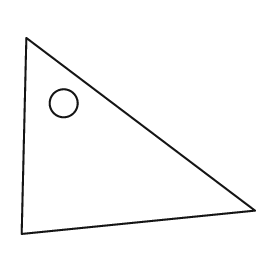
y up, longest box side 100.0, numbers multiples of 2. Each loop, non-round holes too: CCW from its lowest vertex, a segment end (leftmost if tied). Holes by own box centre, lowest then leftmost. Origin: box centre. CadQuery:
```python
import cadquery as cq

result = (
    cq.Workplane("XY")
    .moveTo(-50.0, -42.0)
    .lineTo(50.0, -32.0)
    .lineTo(-48.0, 42.0)
    .close()
    .moveTo(-32.0, 14.0)
    .circle(6.0)
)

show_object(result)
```